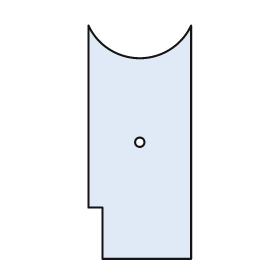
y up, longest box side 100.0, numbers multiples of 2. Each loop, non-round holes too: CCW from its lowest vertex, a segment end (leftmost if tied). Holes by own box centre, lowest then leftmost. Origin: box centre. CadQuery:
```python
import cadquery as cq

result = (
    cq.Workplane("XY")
    .moveTo(-16.0, -50.0)
    .lineTo(22.0, -50.0)
    .lineTo(22.0, 50.0)
    .threePointArc((0.0, 36.0), (-22.0, 50.0))
    .lineTo(-22.0, -28.0)
    .lineTo(-16.0, -28.0)
    .close()
    .moveTo(0.0, 0.0)
    .circle(2.0)
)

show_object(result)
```